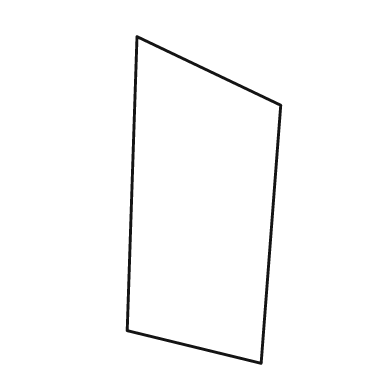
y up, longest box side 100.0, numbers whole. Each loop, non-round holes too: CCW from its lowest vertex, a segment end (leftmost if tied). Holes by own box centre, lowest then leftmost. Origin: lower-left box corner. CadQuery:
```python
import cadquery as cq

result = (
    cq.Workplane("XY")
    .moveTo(41.0, 0.0)
    .lineTo(47.0, 79.0)
    .lineTo(3.0, 100.0)
    .lineTo(0.0, 10.0)
    .close()
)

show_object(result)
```